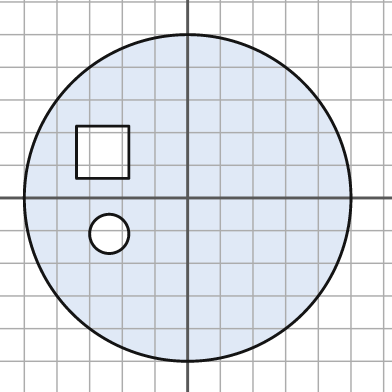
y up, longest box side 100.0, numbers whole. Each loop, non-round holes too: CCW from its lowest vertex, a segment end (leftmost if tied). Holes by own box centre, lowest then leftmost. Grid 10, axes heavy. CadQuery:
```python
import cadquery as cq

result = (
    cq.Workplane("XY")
    .moveTo(0.0, 0.0)
    .circle(50.0)
    .moveTo(-24.0, -11.0)
    .circle(6.0)
    .moveTo(-34.0, 6.0)
    .lineTo(-18.0, 6.0)
    .lineTo(-18.0, 22.0)
    .lineTo(-34.0, 22.0)
    .close()
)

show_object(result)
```